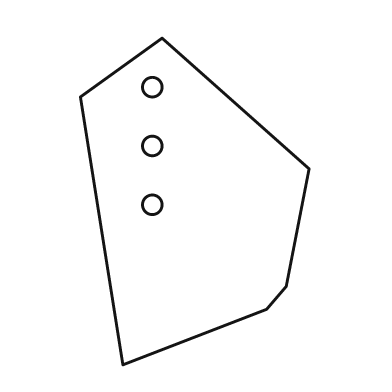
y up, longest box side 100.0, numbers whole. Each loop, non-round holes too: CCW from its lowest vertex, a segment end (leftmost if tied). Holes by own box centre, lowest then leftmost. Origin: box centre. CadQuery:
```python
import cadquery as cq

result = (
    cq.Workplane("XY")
    .moveTo(-22.0, -50.0)
    .lineTo(22.0, -33.0)
    .lineTo(28.0, -26.0)
    .lineTo(35.0, 10.0)
    .lineTo(-10.0, 50.0)
    .lineTo(-35.0, 32.0)
    .close()
    .moveTo(-13.0, -1.0)
    .circle(3.0)
    .moveTo(-13.0, 17.0)
    .circle(3.0)
    .moveTo(-13.0, 35.0)
    .circle(3.0)
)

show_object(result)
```